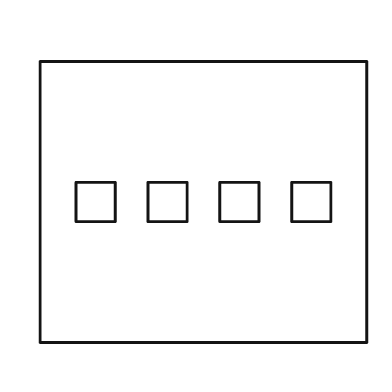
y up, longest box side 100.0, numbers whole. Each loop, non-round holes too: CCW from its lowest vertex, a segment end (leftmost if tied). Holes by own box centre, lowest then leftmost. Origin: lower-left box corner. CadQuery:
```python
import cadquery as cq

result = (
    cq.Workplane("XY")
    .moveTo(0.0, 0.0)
    .lineTo(100.0, 0.0)
    .lineTo(100.0, 86.0)
    .lineTo(0.0, 86.0)
    .close()
    .moveTo(11.0, 37.0)
    .lineTo(23.0, 37.0)
    .lineTo(23.0, 49.0)
    .lineTo(11.0, 49.0)
    .close()
    .moveTo(33.0, 37.0)
    .lineTo(45.0, 37.0)
    .lineTo(45.0, 49.0)
    .lineTo(33.0, 49.0)
    .close()
    .moveTo(55.0, 37.0)
    .lineTo(67.0, 37.0)
    .lineTo(67.0, 49.0)
    .lineTo(55.0, 49.0)
    .close()
    .moveTo(77.0, 37.0)
    .lineTo(89.0, 37.0)
    .lineTo(89.0, 49.0)
    .lineTo(77.0, 49.0)
    .close()
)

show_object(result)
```